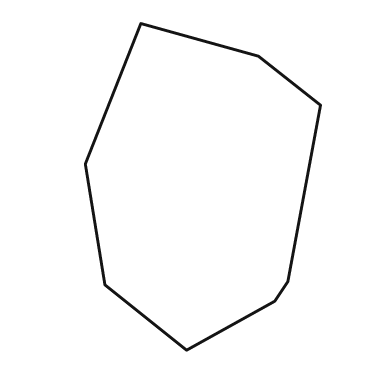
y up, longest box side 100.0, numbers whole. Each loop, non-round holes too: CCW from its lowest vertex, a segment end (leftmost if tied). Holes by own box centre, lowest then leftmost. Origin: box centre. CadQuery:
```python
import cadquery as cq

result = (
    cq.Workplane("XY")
    .moveTo(-5.0, -50.0)
    .lineTo(22.0, -35.0)
    .lineTo(26.0, -29.0)
    .lineTo(36.0, 25.0)
    .lineTo(17.0, 40.0)
    .lineTo(-19.0, 50.0)
    .lineTo(-36.0, 7.0)
    .lineTo(-30.0, -30.0)
    .close()
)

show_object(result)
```